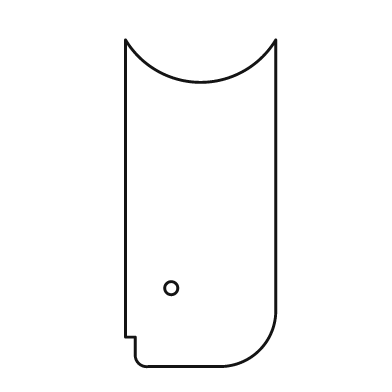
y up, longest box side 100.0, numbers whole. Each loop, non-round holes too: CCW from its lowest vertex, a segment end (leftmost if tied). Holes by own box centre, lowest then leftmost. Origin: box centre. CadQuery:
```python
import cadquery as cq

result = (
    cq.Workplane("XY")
    .moveTo(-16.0, -50.0)
    .lineTo(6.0, -50.0)
    .threePointArc((18.0, -45.0), (23.0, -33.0))
    .lineTo(23.0, 50.0)
    .threePointArc((0.0, 37.0), (-23.0, 50.0))
    .lineTo(-23.0, -41.0)
    .lineTo(-20.0, -41.0)
    .lineTo(-20.0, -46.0)
    .threePointArc((-19.0, -49.0), (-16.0, -50.0))
    .close()
    .moveTo(-9.0, -26.0)
    .circle(2.0)
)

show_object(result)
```